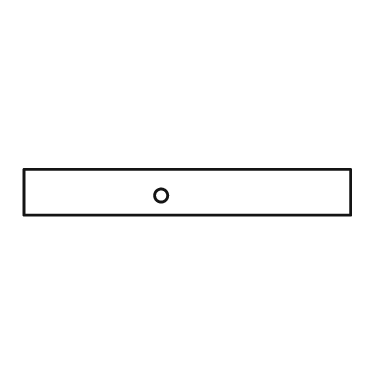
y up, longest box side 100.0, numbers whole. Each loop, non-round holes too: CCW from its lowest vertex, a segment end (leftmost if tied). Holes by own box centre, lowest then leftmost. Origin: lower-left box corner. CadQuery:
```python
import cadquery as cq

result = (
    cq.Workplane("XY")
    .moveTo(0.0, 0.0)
    .lineTo(100.0, 0.0)
    .lineTo(100.0, 14.0)
    .lineTo(0.0, 14.0)
    .close()
    .moveTo(42.0, 6.0)
    .circle(2.0)
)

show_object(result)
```